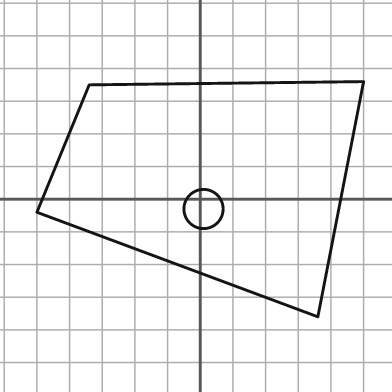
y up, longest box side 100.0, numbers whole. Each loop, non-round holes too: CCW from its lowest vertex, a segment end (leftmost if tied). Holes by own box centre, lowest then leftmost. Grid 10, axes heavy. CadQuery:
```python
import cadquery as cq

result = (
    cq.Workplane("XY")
    .moveTo(36.0, -36.0)
    .lineTo(50.0, 36.0)
    .lineTo(-34.0, 35.0)
    .lineTo(-50.0, -4.0)
    .close()
    .moveTo(1.0, -3.0)
    .circle(6.0)
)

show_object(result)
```